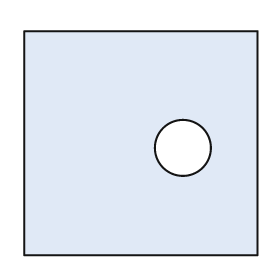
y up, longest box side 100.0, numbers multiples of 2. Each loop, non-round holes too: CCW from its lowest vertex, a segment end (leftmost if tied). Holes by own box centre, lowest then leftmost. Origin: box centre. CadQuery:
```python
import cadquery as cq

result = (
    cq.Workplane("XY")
    .moveTo(-50.0, -48.0)
    .lineTo(50.0, -48.0)
    .lineTo(50.0, 48.0)
    .lineTo(-50.0, 48.0)
    .close()
    .moveTo(18.0, -2.0)
    .circle(12.0)
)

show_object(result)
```